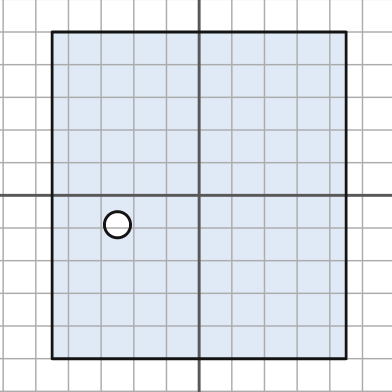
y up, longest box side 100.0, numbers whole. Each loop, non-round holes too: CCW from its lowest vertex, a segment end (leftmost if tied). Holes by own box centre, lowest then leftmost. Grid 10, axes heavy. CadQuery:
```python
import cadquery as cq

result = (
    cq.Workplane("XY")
    .moveTo(-45.0, -50.0)
    .lineTo(45.0, -50.0)
    .lineTo(45.0, 50.0)
    .lineTo(-45.0, 50.0)
    .close()
    .moveTo(-25.0, -9.0)
    .circle(4.0)
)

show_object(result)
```